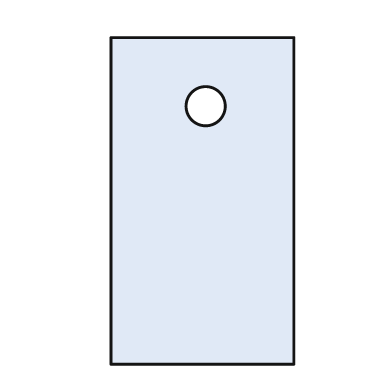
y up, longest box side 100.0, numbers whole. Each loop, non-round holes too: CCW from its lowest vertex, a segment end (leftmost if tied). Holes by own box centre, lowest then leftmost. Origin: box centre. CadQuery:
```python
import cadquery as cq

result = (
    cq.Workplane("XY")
    .moveTo(-28.0, -50.0)
    .lineTo(28.0, -50.0)
    .lineTo(28.0, 50.0)
    .lineTo(-28.0, 50.0)
    .close()
    .moveTo(1.0, 29.0)
    .circle(6.0)
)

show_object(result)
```